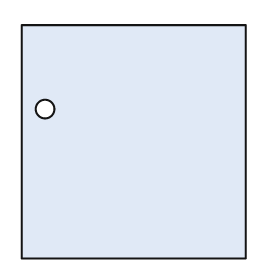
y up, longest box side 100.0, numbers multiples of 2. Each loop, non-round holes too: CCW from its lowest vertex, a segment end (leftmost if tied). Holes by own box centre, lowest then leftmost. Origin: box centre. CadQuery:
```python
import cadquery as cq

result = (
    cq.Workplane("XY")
    .moveTo(-48.0, -50.0)
    .lineTo(48.0, -50.0)
    .lineTo(48.0, 50.0)
    .lineTo(-48.0, 50.0)
    .close()
    .moveTo(-38.0, 14.0)
    .circle(4.0)
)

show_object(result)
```